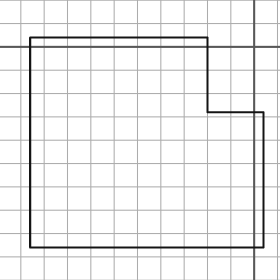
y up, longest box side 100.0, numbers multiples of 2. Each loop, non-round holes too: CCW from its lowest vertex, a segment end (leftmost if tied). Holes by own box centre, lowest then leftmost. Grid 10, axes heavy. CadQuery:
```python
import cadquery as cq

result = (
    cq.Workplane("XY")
    .moveTo(-96.0, -86.0)
    .lineTo(4.0, -86.0)
    .lineTo(4.0, -28.0)
    .lineTo(-20.0, -28.0)
    .lineTo(-20.0, 4.0)
    .lineTo(-96.0, 4.0)
    .close()
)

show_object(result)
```